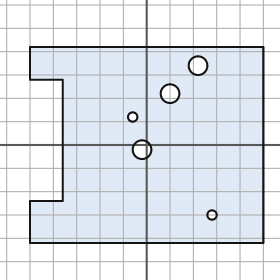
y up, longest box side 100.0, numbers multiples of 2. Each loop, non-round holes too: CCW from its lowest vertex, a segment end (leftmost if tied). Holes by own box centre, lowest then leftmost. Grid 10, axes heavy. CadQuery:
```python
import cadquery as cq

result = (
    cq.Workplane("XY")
    .moveTo(-50.0, -42.0)
    .lineTo(50.0, -42.0)
    .lineTo(50.0, 42.0)
    .lineTo(-50.0, 42.0)
    .lineTo(-50.0, 28.0)
    .lineTo(-36.0, 28.0)
    .lineTo(-36.0, -24.0)
    .lineTo(-50.0, -24.0)
    .close()
    .moveTo(28.0, -30.0)
    .circle(2.0)
    .moveTo(-2.0, -2.0)
    .circle(4.0)
    .moveTo(-6.0, 12.0)
    .circle(2.0)
    .moveTo(10.0, 22.0)
    .circle(4.0)
    .moveTo(22.0, 34.0)
    .circle(4.0)
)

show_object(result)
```